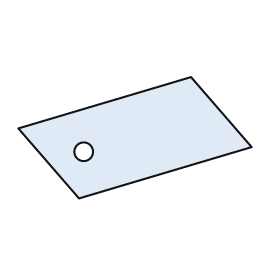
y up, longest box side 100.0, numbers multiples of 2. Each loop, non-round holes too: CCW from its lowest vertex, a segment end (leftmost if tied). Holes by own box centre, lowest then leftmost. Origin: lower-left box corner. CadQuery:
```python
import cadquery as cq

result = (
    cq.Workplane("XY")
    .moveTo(26.0, 0.0)
    .lineTo(100.0, 22.0)
    .lineTo(74.0, 52.0)
    .lineTo(0.0, 30.0)
    .close()
    .moveTo(28.0, 20.0)
    .circle(4.0)
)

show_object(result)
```